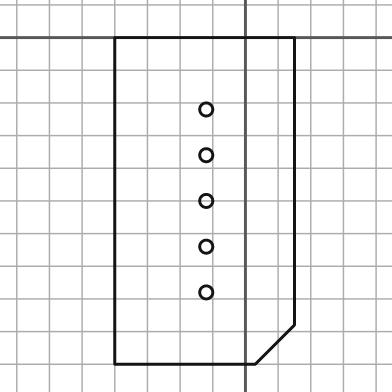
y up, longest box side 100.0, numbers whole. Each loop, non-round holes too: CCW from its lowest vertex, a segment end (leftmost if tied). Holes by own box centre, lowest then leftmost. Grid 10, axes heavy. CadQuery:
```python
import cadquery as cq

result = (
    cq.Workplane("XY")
    .moveTo(-40.0, -100.0)
    .lineTo(3.0, -100.0)
    .lineTo(15.0, -88.0)
    .lineTo(15.0, 0.0)
    .lineTo(-40.0, 0.0)
    .close()
    .moveTo(-12.0, -78.0)
    .circle(2.0)
    .moveTo(-12.0, -64.0)
    .circle(2.0)
    .moveTo(-12.0, -50.0)
    .circle(2.0)
    .moveTo(-12.0, -36.0)
    .circle(2.0)
    .moveTo(-12.0, -22.0)
    .circle(2.0)
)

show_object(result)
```